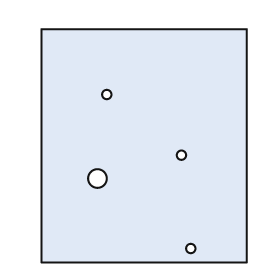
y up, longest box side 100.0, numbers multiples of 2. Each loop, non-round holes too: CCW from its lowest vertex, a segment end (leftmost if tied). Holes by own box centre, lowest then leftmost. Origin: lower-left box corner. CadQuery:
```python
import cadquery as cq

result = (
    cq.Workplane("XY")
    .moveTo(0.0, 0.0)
    .lineTo(88.0, 0.0)
    .lineTo(88.0, 100.0)
    .lineTo(0.0, 100.0)
    .close()
    .moveTo(64.0, 6.0)
    .circle(2.0)
    .moveTo(24.0, 36.0)
    .circle(4.0)
    .moveTo(60.0, 46.0)
    .circle(2.0)
    .moveTo(28.0, 72.0)
    .circle(2.0)
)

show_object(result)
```